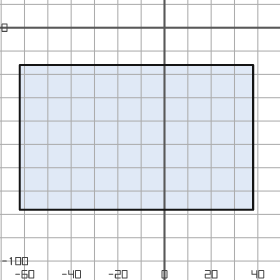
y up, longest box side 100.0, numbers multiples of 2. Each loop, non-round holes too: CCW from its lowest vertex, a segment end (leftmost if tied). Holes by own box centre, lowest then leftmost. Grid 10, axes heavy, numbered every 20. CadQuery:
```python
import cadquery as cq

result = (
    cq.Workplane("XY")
    .moveTo(-62.0, -78.0)
    .lineTo(38.0, -78.0)
    .lineTo(38.0, -16.0)
    .lineTo(-62.0, -16.0)
    .close()
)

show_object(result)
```